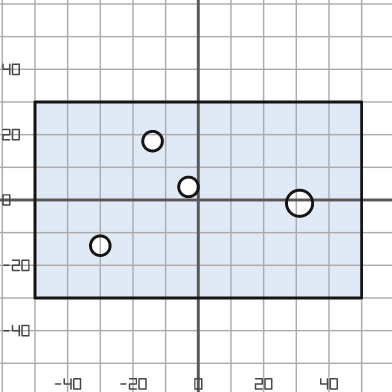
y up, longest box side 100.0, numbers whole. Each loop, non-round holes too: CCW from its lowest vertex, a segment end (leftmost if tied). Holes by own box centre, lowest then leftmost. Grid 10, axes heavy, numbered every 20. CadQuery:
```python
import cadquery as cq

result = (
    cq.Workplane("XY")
    .moveTo(-50.0, -30.0)
    .lineTo(50.0, -30.0)
    .lineTo(50.0, 30.0)
    .lineTo(-50.0, 30.0)
    .close()
    .moveTo(-30.0, -14.0)
    .circle(3.0)
    .moveTo(31.0, -1.0)
    .circle(4.0)
    .moveTo(-3.0, 4.0)
    .circle(3.0)
    .moveTo(-14.0, 18.0)
    .circle(3.0)
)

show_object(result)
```